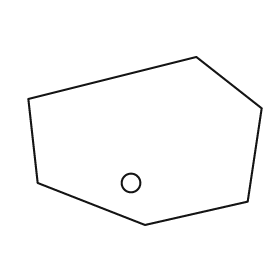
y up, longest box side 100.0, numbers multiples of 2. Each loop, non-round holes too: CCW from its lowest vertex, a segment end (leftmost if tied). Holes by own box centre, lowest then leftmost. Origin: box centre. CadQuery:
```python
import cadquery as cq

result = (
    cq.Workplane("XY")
    .moveTo(0.0, -36.0)
    .lineTo(44.0, -26.0)
    .lineTo(50.0, 14.0)
    .lineTo(22.0, 36.0)
    .lineTo(-50.0, 18.0)
    .lineTo(-46.0, -18.0)
    .close()
    .moveTo(-6.0, -18.0)
    .circle(4.0)
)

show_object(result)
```